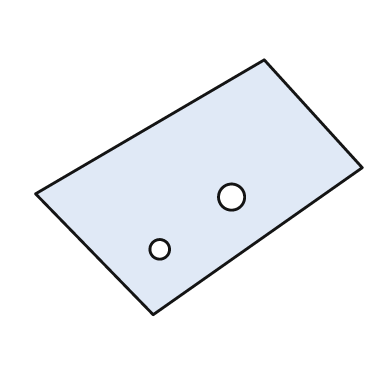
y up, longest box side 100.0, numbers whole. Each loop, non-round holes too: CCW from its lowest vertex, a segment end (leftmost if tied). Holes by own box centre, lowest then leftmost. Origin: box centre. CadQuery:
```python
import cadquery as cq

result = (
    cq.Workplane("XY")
    .moveTo(-14.0, -39.0)
    .lineTo(50.0, 6.0)
    .lineTo(20.0, 39.0)
    .lineTo(-50.0, -2.0)
    .close()
    .moveTo(-12.0, -19.0)
    .circle(3.0)
    .moveTo(10.0, -3.0)
    .circle(4.0)
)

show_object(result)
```